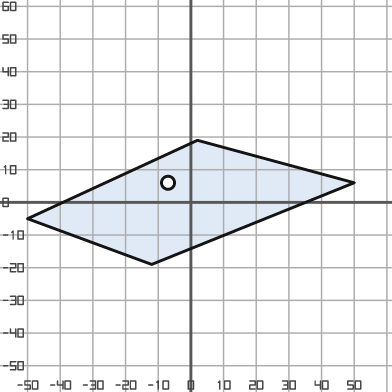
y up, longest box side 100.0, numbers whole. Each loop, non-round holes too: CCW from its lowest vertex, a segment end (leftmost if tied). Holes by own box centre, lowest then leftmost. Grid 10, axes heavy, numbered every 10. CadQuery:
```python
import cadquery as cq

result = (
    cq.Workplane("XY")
    .moveTo(-12.0, -19.0)
    .lineTo(50.0, 6.0)
    .lineTo(2.0, 19.0)
    .lineTo(-50.0, -5.0)
    .close()
    .moveTo(-7.0, 6.0)
    .circle(2.0)
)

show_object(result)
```